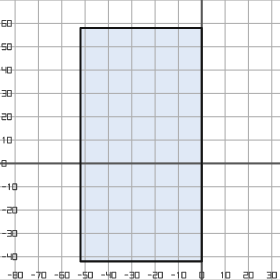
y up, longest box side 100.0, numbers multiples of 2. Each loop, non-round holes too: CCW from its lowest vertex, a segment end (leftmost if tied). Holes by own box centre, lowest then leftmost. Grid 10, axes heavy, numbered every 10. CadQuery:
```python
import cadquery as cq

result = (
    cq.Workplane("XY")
    .moveTo(-52.0, -42.0)
    .lineTo(0.0, -42.0)
    .lineTo(0.0, 58.0)
    .lineTo(-52.0, 58.0)
    .close()
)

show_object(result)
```